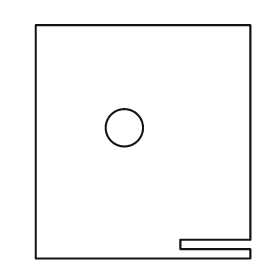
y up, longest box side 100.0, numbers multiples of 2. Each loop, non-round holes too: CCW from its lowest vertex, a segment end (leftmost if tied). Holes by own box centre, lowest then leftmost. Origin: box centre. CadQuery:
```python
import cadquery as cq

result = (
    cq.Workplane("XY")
    .moveTo(-46.0, -50.0)
    .lineTo(46.0, -50.0)
    .lineTo(46.0, -46.0)
    .lineTo(16.0, -46.0)
    .lineTo(16.0, -42.0)
    .lineTo(46.0, -42.0)
    .lineTo(46.0, 50.0)
    .lineTo(-46.0, 50.0)
    .close()
    .moveTo(-8.0, 6.0)
    .circle(8.0)
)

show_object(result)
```